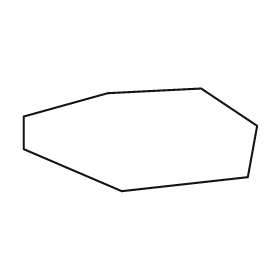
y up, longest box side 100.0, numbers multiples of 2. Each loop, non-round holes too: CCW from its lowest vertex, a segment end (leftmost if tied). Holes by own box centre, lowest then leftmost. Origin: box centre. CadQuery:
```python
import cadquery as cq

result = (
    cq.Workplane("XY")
    .moveTo(-8.0, -22.0)
    .lineTo(46.0, -16.0)
    .lineTo(50.0, 6.0)
    .lineTo(26.0, 22.0)
    .lineTo(-14.0, 20.0)
    .lineTo(-50.0, 10.0)
    .lineTo(-50.0, -4.0)
    .close()
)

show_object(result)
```